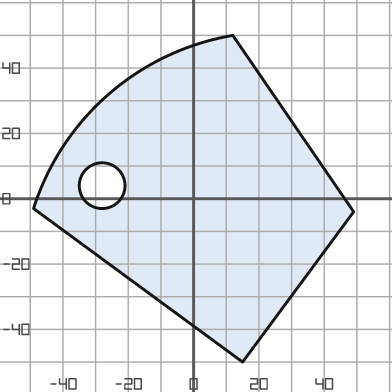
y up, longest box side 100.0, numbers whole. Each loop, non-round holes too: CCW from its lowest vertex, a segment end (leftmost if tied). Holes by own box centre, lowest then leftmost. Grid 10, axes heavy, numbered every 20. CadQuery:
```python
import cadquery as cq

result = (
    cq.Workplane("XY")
    .moveTo(15.0, -50.0)
    .lineTo(49.0, -4.0)
    .lineTo(12.0, 50.0)
    .threePointArc((-26.0, 32.0), (-49.0, -3.0))
    .close()
    .moveTo(-28.0, 4.0)
    .circle(7.0)
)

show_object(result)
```